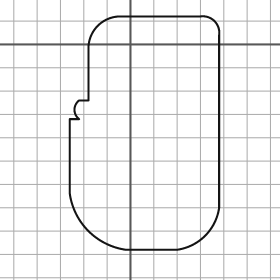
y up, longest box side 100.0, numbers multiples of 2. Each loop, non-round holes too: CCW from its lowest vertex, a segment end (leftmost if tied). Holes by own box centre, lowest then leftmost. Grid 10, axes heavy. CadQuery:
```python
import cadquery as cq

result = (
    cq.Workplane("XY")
    .moveTo(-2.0, -88.0)
    .lineTo(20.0, -88.0)
    .threePointArc((32.0, -82.0), (38.0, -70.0))
    .lineTo(38.0, 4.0)
    .threePointArc((36.0, 10.0), (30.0, 12.0))
    .lineTo(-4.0, 12.0)
    .threePointArc((-14.0, 8.0), (-18.0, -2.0))
    .lineTo(-18.0, -24.0)
    .lineTo(-22.0, -24.0)
    .threePointArc((-24.0, -28.0), (-22.0, -32.0))
    .lineTo(-26.0, -32.0)
    .lineTo(-26.0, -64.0)
    .threePointArc((-18.0, -80.0), (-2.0, -88.0))
    .close()
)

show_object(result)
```